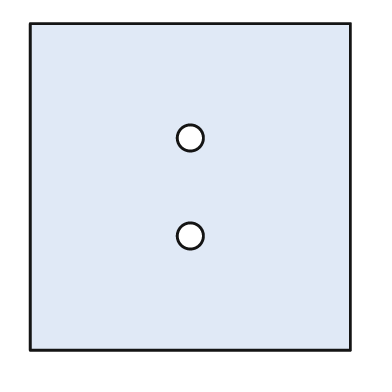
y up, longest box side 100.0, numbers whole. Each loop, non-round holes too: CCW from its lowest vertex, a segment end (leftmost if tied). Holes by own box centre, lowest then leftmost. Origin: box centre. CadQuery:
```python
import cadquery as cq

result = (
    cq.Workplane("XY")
    .moveTo(-49.0, -50.0)
    .lineTo(49.0, -50.0)
    .lineTo(49.0, 50.0)
    .lineTo(-49.0, 50.0)
    .close()
    .moveTo(0.0, -15.0)
    .circle(4.0)
    .moveTo(0.0, 15.0)
    .circle(4.0)
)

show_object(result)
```